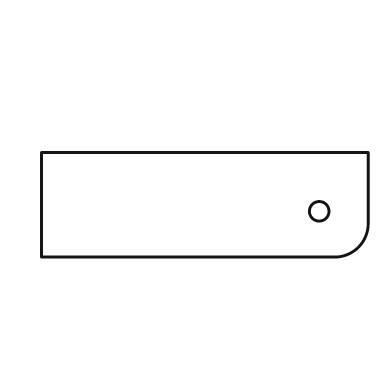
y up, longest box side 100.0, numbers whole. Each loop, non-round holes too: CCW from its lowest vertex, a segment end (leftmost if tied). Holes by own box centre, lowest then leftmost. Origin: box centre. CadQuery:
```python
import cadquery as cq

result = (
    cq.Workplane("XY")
    .moveTo(-50.0, -16.0)
    .lineTo(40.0, -16.0)
    .threePointArc((47.0, -13.0), (50.0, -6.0))
    .lineTo(50.0, 16.0)
    .lineTo(-50.0, 16.0)
    .close()
    .moveTo(35.0, -2.0)
    .circle(3.0)
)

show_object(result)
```